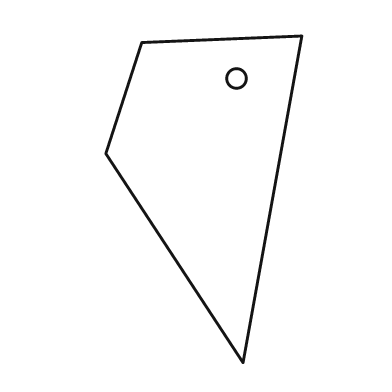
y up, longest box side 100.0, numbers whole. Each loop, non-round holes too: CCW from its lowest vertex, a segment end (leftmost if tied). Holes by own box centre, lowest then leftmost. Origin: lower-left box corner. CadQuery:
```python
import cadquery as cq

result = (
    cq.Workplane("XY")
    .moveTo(42.0, 0.0)
    .lineTo(60.0, 100.0)
    .lineTo(11.0, 98.0)
    .lineTo(0.0, 64.0)
    .close()
    .moveTo(40.0, 87.0)
    .circle(3.0)
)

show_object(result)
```